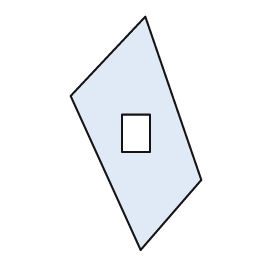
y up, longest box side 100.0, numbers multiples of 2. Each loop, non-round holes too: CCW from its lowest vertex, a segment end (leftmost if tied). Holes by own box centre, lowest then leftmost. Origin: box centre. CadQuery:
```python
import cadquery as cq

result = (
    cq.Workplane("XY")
    .moveTo(2.0, -50.0)
    .lineTo(28.0, -20.0)
    .lineTo(4.0, 50.0)
    .lineTo(-28.0, 16.0)
    .close()
    .moveTo(-6.0, -8.0)
    .lineTo(6.0, -8.0)
    .lineTo(6.0, 8.0)
    .lineTo(-6.0, 8.0)
    .close()
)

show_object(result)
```